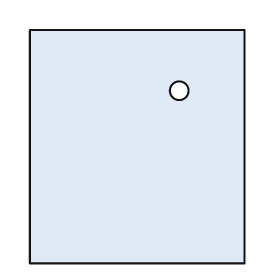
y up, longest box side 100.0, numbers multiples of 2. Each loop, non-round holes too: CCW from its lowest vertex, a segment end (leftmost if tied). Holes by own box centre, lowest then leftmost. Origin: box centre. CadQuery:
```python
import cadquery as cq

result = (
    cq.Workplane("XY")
    .moveTo(-46.0, -50.0)
    .lineTo(46.0, -50.0)
    .lineTo(46.0, 50.0)
    .lineTo(-46.0, 50.0)
    .close()
    .moveTo(18.0, 24.0)
    .circle(4.0)
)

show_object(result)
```